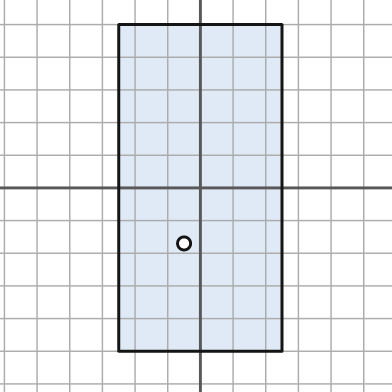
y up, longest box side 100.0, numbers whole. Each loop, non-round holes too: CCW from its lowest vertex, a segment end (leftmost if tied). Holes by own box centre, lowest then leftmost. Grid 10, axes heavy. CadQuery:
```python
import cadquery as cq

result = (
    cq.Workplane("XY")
    .moveTo(-25.0, -50.0)
    .lineTo(25.0, -50.0)
    .lineTo(25.0, 50.0)
    .lineTo(-25.0, 50.0)
    .close()
    .moveTo(-5.0, -17.0)
    .circle(2.0)
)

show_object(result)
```